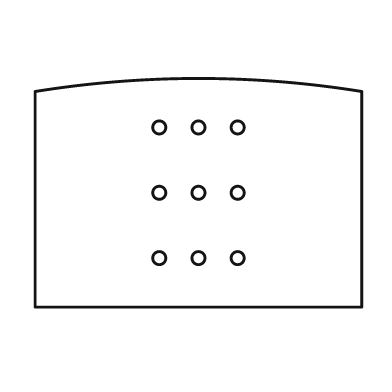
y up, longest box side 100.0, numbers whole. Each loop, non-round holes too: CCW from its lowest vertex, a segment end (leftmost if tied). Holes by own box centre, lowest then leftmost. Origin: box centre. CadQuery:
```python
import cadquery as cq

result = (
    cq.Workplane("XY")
    .moveTo(-50.0, -35.0)
    .lineTo(50.0, -35.0)
    .lineTo(50.0, 31.0)
    .threePointArc((0.0, 35.0), (-50.0, 31.0))
    .close()
    .moveTo(-12.0, -20.0)
    .circle(2.0)
    .moveTo(0.0, -20.0)
    .circle(2.0)
    .moveTo(12.0, -20.0)
    .circle(2.0)
    .moveTo(-12.0, 0.0)
    .circle(2.0)
    .moveTo(0.0, 0.0)
    .circle(2.0)
    .moveTo(12.0, 0.0)
    .circle(2.0)
    .moveTo(-12.0, 20.0)
    .circle(2.0)
    .moveTo(0.0, 20.0)
    .circle(2.0)
    .moveTo(12.0, 20.0)
    .circle(2.0)
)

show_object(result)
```